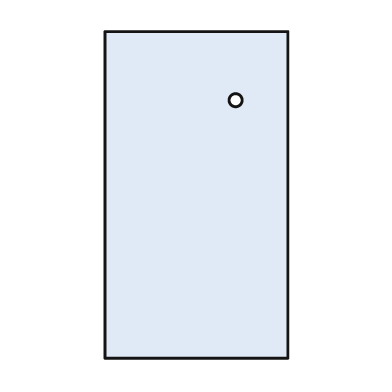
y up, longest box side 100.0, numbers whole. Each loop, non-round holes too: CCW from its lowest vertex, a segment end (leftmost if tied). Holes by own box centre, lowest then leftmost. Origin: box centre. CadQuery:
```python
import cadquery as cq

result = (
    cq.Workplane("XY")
    .moveTo(-28.0, -50.0)
    .lineTo(28.0, -50.0)
    .lineTo(28.0, 50.0)
    .lineTo(-28.0, 50.0)
    .close()
    .moveTo(12.0, 29.0)
    .circle(2.0)
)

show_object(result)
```